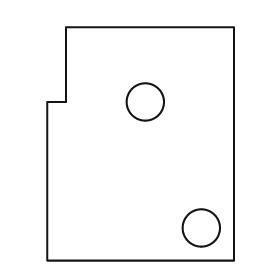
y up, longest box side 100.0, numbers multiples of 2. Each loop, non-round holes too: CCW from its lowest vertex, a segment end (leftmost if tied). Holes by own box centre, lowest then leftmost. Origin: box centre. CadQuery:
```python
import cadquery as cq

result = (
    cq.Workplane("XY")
    .moveTo(-40.0, -50.0)
    .lineTo(40.0, -50.0)
    .lineTo(40.0, 50.0)
    .lineTo(-32.0, 50.0)
    .lineTo(-32.0, 18.0)
    .lineTo(-40.0, 18.0)
    .close()
    .moveTo(26.0, -36.0)
    .circle(8.0)
    .moveTo(2.0, 18.0)
    .circle(8.0)
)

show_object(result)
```